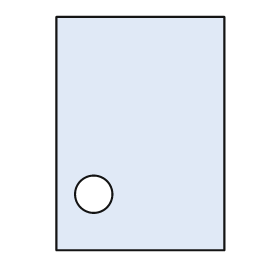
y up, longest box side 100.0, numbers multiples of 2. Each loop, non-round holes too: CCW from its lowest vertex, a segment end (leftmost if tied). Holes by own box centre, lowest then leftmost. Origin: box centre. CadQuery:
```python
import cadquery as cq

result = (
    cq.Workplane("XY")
    .moveTo(-36.0, -50.0)
    .lineTo(36.0, -50.0)
    .lineTo(36.0, 50.0)
    .lineTo(-36.0, 50.0)
    .close()
    .moveTo(-20.0, -26.0)
    .circle(8.0)
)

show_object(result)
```